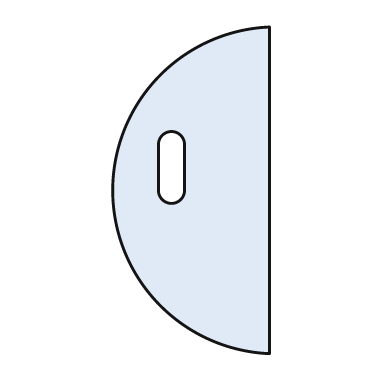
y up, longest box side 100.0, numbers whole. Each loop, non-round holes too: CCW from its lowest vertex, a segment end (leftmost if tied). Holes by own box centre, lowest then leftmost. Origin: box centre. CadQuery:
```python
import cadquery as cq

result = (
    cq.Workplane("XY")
    .moveTo(24.0, -50.0)
    .lineTo(24.0, 50.0)
    .threePointArc((-24.0, 0.0), (24.0, -50.0))
    .close()
    .moveTo(-10.0, 0.0)
    .threePointArc((-6.0, -4.0), (-2.0, 0.0))
    .lineTo(-2.0, 14.0)
    .threePointArc((-6.0, 18.0), (-10.0, 14.0))
    .close()
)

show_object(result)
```